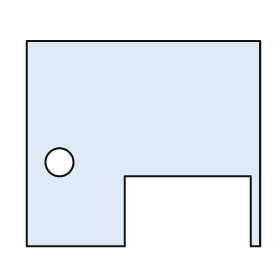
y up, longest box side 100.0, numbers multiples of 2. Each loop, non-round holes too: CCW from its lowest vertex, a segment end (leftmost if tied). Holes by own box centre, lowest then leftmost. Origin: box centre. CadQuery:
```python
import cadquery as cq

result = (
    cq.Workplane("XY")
    .moveTo(-50.0, -44.0)
    .lineTo(-8.0, -44.0)
    .lineTo(-8.0, -14.0)
    .lineTo(46.0, -14.0)
    .lineTo(46.0, -44.0)
    .lineTo(50.0, -44.0)
    .lineTo(50.0, 44.0)
    .lineTo(-50.0, 44.0)
    .close()
    .moveTo(-36.0, -8.0)
    .circle(6.0)
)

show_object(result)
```